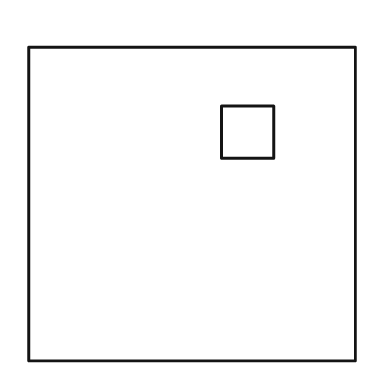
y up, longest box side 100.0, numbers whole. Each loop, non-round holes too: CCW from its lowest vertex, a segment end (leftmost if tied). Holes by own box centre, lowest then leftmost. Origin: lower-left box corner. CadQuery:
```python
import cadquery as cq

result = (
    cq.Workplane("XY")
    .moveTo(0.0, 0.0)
    .lineTo(100.0, 0.0)
    .lineTo(100.0, 96.0)
    .lineTo(0.0, 96.0)
    .close()
    .moveTo(59.0, 62.0)
    .lineTo(75.0, 62.0)
    .lineTo(75.0, 78.0)
    .lineTo(59.0, 78.0)
    .close()
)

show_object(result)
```